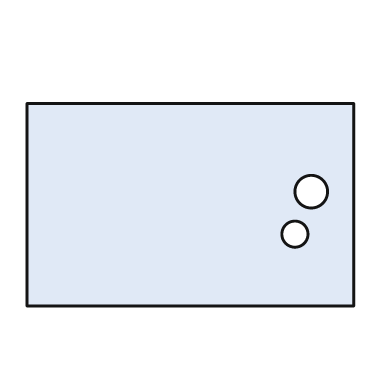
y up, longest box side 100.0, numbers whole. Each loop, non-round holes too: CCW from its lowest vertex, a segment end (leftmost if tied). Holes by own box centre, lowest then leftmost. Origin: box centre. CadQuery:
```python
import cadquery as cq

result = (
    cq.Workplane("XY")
    .moveTo(-50.0, -31.0)
    .lineTo(50.0, -31.0)
    .lineTo(50.0, 31.0)
    .lineTo(-50.0, 31.0)
    .close()
    .moveTo(32.0, -9.0)
    .circle(4.0)
    .moveTo(37.0, 4.0)
    .circle(5.0)
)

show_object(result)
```